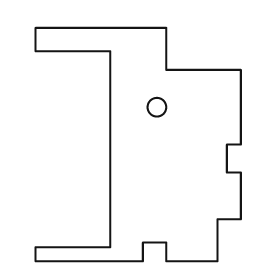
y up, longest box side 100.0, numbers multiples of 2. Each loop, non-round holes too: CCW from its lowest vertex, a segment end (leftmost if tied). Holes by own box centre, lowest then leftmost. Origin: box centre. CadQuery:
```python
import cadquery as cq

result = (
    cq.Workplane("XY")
    .moveTo(-44.0, -50.0)
    .lineTo(2.0, -50.0)
    .lineTo(2.0, -42.0)
    .lineTo(12.0, -42.0)
    .lineTo(12.0, -50.0)
    .lineTo(34.0, -50.0)
    .lineTo(34.0, -32.0)
    .lineTo(44.0, -32.0)
    .lineTo(44.0, -12.0)
    .lineTo(38.0, -12.0)
    .lineTo(38.0, 0.0)
    .lineTo(44.0, 0.0)
    .lineTo(44.0, 32.0)
    .lineTo(12.0, 32.0)
    .lineTo(12.0, 50.0)
    .lineTo(-44.0, 50.0)
    .lineTo(-44.0, 40.0)
    .lineTo(-12.0, 40.0)
    .lineTo(-12.0, -44.0)
    .lineTo(-44.0, -44.0)
    .close()
    .moveTo(8.0, 16.0)
    .circle(4.0)
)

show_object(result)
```